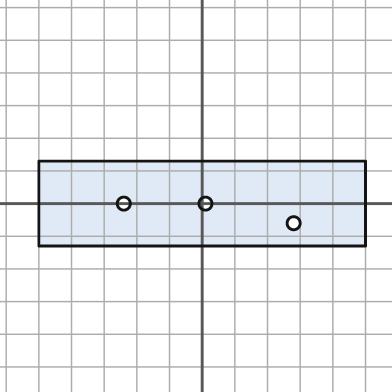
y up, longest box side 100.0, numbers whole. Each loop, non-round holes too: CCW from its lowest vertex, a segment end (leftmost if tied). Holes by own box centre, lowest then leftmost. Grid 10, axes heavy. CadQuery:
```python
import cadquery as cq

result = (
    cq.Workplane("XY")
    .moveTo(-50.0, -13.0)
    .lineTo(50.0, -13.0)
    .lineTo(50.0, 13.0)
    .lineTo(-50.0, 13.0)
    .close()
    .moveTo(28.0, -6.0)
    .circle(2.0)
    .moveTo(-24.0, 0.0)
    .circle(2.0)
    .moveTo(1.0, 0.0)
    .circle(2.0)
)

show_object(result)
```